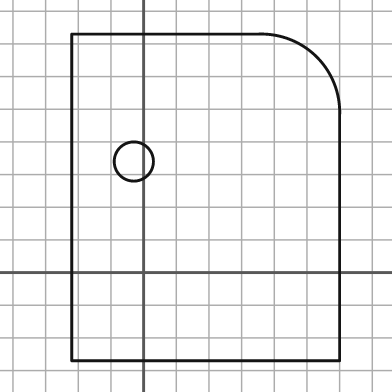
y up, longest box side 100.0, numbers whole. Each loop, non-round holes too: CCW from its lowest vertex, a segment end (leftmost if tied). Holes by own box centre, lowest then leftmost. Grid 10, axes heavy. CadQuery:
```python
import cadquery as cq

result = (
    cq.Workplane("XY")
    .moveTo(-22.0, -27.0)
    .lineTo(60.0, -27.0)
    .lineTo(60.0, 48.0)
    .threePointArc((53.0, 66.0), (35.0, 73.0))
    .lineTo(-22.0, 73.0)
    .close()
    .moveTo(-3.0, 34.0)
    .circle(6.0)
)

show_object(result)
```